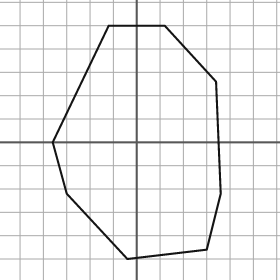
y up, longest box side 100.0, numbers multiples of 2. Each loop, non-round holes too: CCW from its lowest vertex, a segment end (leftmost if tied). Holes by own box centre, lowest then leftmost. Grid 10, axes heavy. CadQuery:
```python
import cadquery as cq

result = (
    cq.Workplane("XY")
    .moveTo(-4.0, -50.0)
    .lineTo(30.0, -46.0)
    .lineTo(36.0, -22.0)
    .lineTo(34.0, 26.0)
    .lineTo(12.0, 50.0)
    .lineTo(-12.0, 50.0)
    .lineTo(-36.0, 0.0)
    .lineTo(-30.0, -22.0)
    .close()
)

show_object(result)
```